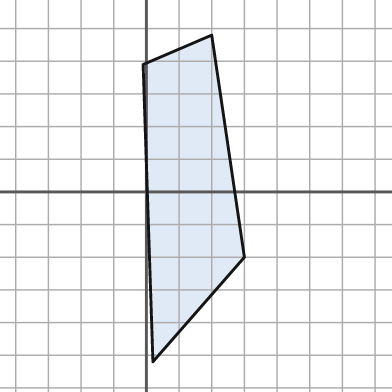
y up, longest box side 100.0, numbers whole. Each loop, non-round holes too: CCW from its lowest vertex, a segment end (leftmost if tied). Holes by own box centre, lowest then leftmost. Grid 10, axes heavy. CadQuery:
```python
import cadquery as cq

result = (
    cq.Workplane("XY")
    .moveTo(2.0, -52.0)
    .lineTo(30.0, -20.0)
    .lineTo(20.0, 48.0)
    .lineTo(-1.0, 39.0)
    .close()
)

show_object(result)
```